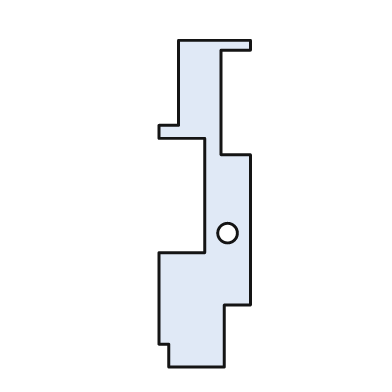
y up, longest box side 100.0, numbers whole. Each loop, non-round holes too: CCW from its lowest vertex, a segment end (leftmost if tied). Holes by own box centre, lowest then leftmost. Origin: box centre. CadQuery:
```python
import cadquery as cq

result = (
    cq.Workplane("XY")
    .moveTo(-11.0, -50.0)
    .lineTo(6.0, -50.0)
    .lineTo(6.0, -31.0)
    .lineTo(14.0, -31.0)
    .lineTo(14.0, 15.0)
    .lineTo(5.0, 15.0)
    .lineTo(5.0, 47.0)
    .lineTo(14.0, 47.0)
    .lineTo(14.0, 50.0)
    .lineTo(-8.0, 50.0)
    .lineTo(-8.0, 24.0)
    .lineTo(-14.0, 24.0)
    .lineTo(-14.0, 20.0)
    .lineTo(0.0, 20.0)
    .lineTo(0.0, -15.0)
    .lineTo(-14.0, -15.0)
    .lineTo(-14.0, -43.0)
    .lineTo(-11.0, -43.0)
    .close()
    .moveTo(7.0, -9.0)
    .circle(3.0)
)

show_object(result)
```